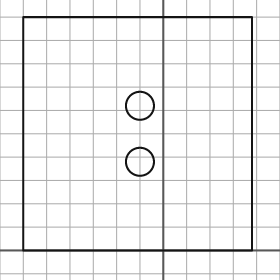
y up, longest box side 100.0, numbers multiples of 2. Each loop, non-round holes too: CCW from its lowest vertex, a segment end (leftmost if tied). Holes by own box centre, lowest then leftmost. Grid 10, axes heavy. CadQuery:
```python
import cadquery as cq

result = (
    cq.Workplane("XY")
    .moveTo(-60.0, 0.0)
    .lineTo(38.0, 0.0)
    .lineTo(38.0, 100.0)
    .lineTo(-60.0, 100.0)
    .close()
    .moveTo(-10.0, 38.0)
    .circle(6.0)
    .moveTo(-10.0, 62.0)
    .circle(6.0)
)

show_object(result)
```